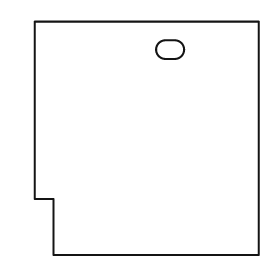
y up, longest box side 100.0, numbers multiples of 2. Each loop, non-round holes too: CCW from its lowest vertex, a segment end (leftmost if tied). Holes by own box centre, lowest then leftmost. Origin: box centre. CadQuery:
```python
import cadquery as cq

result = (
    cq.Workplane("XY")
    .moveTo(-40.0, -50.0)
    .lineTo(48.0, -50.0)
    .lineTo(48.0, 50.0)
    .lineTo(-48.0, 50.0)
    .lineTo(-48.0, -26.0)
    .lineTo(-40.0, -26.0)
    .close()
    .moveTo(8.0, 34.0)
    .lineTo(12.0, 34.0)
    .threePointArc((16.0, 38.0), (12.0, 42.0))
    .lineTo(8.0, 42.0)
    .threePointArc((4.0, 38.0), (8.0, 34.0))
    .close()
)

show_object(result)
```